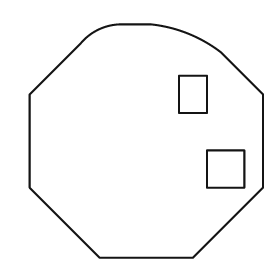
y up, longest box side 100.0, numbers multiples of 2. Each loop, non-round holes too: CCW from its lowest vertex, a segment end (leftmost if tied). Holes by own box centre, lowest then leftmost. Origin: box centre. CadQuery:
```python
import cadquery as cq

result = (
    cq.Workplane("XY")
    .moveTo(-20.0, -50.0)
    .lineTo(20.0, -50.0)
    .lineTo(50.0, -20.0)
    .lineTo(50.0, 20.0)
    .lineTo(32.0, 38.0)
    .threePointArc((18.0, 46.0), (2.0, 50.0))
    .lineTo(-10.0, 50.0)
    .threePointArc((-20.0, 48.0), (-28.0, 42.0))
    .lineTo(-50.0, 20.0)
    .lineTo(-50.0, -20.0)
    .close()
    .moveTo(26.0, -20.0)
    .lineTo(42.0, -20.0)
    .lineTo(42.0, -4.0)
    .lineTo(26.0, -4.0)
    .close()
    .moveTo(14.0, 12.0)
    .lineTo(26.0, 12.0)
    .lineTo(26.0, 28.0)
    .lineTo(14.0, 28.0)
    .close()
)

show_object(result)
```